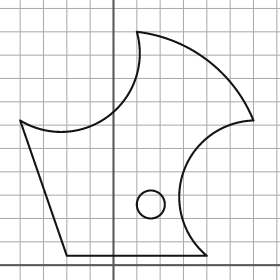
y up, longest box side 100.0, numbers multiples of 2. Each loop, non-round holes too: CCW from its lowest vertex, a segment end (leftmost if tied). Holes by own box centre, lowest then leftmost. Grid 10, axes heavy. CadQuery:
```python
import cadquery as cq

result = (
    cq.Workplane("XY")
    .moveTo(-20.0, 4.0)
    .lineTo(40.0, 4.0)
    .threePointArc((30.0, 40.0), (60.0, 62.0))
    .threePointArc((40.0, 88.0), (10.0, 100.0))
    .threePointArc((-2.0, 64.0), (-40.0, 62.0))
    .close()
    .moveTo(16.0, 26.0)
    .circle(6.0)
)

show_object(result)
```